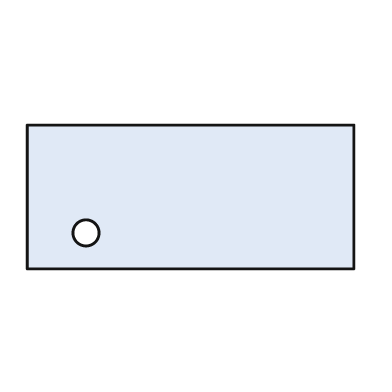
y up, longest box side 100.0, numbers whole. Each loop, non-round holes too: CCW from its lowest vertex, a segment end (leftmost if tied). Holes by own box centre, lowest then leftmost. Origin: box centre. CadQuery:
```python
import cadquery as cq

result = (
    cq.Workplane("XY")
    .moveTo(-50.0, -22.0)
    .lineTo(50.0, -22.0)
    .lineTo(50.0, 22.0)
    .lineTo(-50.0, 22.0)
    .close()
    .moveTo(-32.0, -11.0)
    .circle(4.0)
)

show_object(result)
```